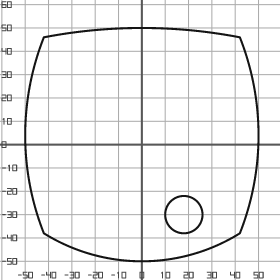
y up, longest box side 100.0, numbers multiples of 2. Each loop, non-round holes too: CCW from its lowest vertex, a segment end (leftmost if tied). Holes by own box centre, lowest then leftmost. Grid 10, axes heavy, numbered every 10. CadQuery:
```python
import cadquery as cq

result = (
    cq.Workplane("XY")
    .moveTo(-42.0, -38.0)
    .threePointArc((0.0, -50.0), (42.0, -38.0))
    .threePointArc((50.0, 4.0), (42.0, 46.0))
    .threePointArc((0.0, 50.0), (-42.0, 46.0))
    .threePointArc((-50.0, 4.0), (-42.0, -38.0))
    .close()
    .moveTo(18.0, -30.0)
    .circle(8.0)
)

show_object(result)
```